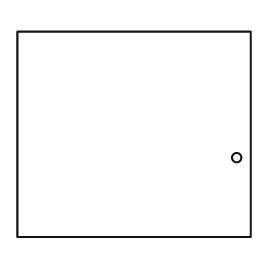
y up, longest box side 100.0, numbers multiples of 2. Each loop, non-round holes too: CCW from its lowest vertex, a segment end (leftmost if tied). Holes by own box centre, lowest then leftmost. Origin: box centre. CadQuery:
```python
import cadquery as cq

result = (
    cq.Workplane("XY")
    .moveTo(-50.0, -44.0)
    .lineTo(50.0, -44.0)
    .lineTo(50.0, 44.0)
    .lineTo(-50.0, 44.0)
    .close()
    .moveTo(44.0, -10.0)
    .circle(2.0)
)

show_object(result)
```